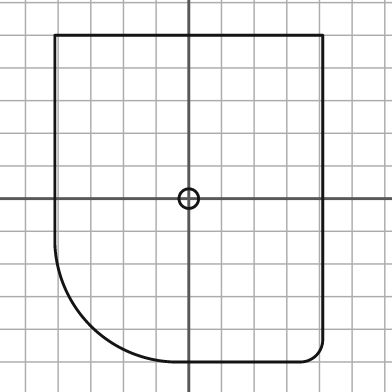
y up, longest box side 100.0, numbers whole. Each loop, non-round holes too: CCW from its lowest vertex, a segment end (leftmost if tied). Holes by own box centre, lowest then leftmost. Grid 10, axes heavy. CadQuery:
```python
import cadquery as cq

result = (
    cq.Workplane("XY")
    .moveTo(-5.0, -50.0)
    .lineTo(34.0, -50.0)
    .threePointArc((39.0, -48.0), (41.0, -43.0))
    .lineTo(41.0, 50.0)
    .lineTo(-41.0, 50.0)
    .lineTo(-41.0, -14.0)
    .threePointArc((-30.0, -39.0), (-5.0, -50.0))
    .close()
    .moveTo(0.0, 0.0)
    .circle(3.0)
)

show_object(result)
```